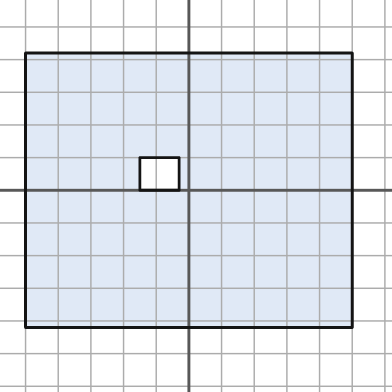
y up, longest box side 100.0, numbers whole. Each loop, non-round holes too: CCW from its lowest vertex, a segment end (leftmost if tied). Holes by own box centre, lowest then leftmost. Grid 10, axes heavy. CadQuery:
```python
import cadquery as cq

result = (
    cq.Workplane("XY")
    .moveTo(-50.0, -42.0)
    .lineTo(50.0, -42.0)
    .lineTo(50.0, 42.0)
    .lineTo(-50.0, 42.0)
    .close()
    .moveTo(-15.0, 0.0)
    .lineTo(-3.0, 0.0)
    .lineTo(-3.0, 10.0)
    .lineTo(-15.0, 10.0)
    .close()
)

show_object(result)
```